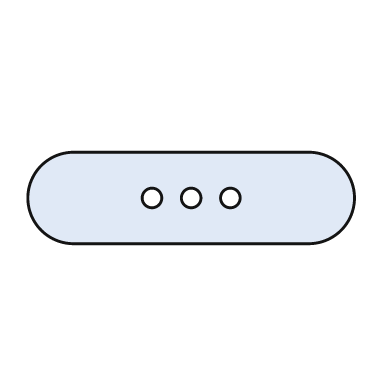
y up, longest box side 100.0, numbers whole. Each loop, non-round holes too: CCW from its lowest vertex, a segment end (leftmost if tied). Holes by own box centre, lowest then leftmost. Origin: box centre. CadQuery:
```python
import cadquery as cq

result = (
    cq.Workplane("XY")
    .moveTo(-36.0, -14.0)
    .lineTo(36.0, -14.0)
    .threePointArc((50.0, 0.0), (36.0, 14.0))
    .lineTo(-36.0, 14.0)
    .threePointArc((-50.0, 0.0), (-36.0, -14.0))
    .close()
    .moveTo(-12.0, 0.0)
    .circle(3.0)
    .moveTo(0.0, 0.0)
    .circle(3.0)
    .moveTo(12.0, 0.0)
    .circle(3.0)
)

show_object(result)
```